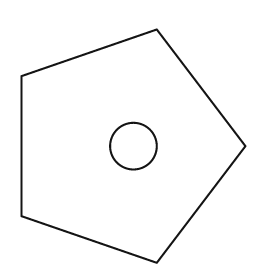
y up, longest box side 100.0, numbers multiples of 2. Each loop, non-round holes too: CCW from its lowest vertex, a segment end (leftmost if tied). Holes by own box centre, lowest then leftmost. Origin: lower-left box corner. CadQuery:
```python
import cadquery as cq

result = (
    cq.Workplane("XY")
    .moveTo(58.0, 0.0)
    .lineTo(96.0, 50.0)
    .lineTo(58.0, 100.0)
    .lineTo(0.0, 80.0)
    .lineTo(0.0, 20.0)
    .close()
    .moveTo(48.0, 50.0)
    .circle(10.0)
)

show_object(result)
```